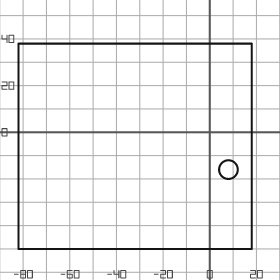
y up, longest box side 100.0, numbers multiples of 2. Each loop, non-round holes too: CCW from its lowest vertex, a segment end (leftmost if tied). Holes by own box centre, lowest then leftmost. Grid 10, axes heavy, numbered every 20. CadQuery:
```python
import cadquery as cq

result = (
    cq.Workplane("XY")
    .moveTo(-82.0, -50.0)
    .lineTo(18.0, -50.0)
    .lineTo(18.0, 38.0)
    .lineTo(-82.0, 38.0)
    .close()
    .moveTo(8.0, -16.0)
    .circle(4.0)
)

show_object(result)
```